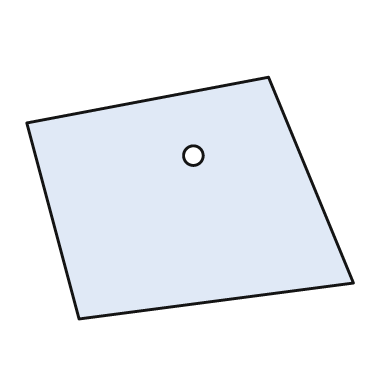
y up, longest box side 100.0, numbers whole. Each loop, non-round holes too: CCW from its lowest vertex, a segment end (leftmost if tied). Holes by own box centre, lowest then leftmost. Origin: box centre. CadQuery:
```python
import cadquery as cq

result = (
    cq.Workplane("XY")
    .moveTo(-34.0, -37.0)
    .lineTo(50.0, -26.0)
    .lineTo(24.0, 37.0)
    .lineTo(-50.0, 23.0)
    .close()
    .moveTo(1.0, 13.0)
    .circle(3.0)
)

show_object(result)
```